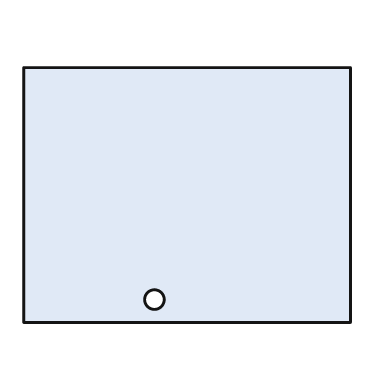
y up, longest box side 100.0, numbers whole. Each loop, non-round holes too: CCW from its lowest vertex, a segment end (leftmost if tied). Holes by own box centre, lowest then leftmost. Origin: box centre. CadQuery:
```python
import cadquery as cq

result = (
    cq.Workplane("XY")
    .moveTo(-50.0, -39.0)
    .lineTo(50.0, -39.0)
    .lineTo(50.0, 39.0)
    .lineTo(-50.0, 39.0)
    .close()
    .moveTo(-10.0, -32.0)
    .circle(3.0)
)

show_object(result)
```